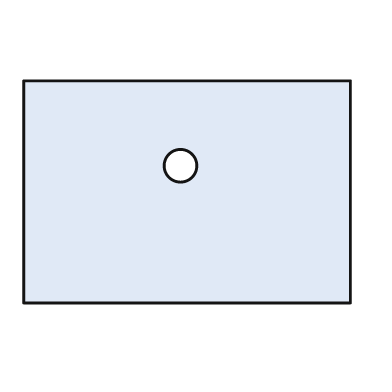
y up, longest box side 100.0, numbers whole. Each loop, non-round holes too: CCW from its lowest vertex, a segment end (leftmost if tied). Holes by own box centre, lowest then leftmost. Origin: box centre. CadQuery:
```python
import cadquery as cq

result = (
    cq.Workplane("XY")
    .moveTo(-50.0, -34.0)
    .lineTo(50.0, -34.0)
    .lineTo(50.0, 34.0)
    .lineTo(-50.0, 34.0)
    .close()
    .moveTo(-2.0, 8.0)
    .circle(5.0)
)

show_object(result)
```